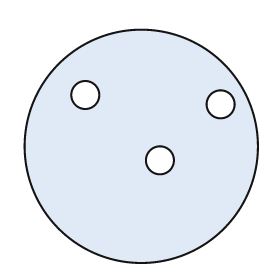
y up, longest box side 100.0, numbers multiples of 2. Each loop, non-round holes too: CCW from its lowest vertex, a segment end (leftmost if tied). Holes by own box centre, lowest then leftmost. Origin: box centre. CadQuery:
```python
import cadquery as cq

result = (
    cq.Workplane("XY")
    .moveTo(0.0, 0.0)
    .circle(50.0)
    .moveTo(8.0, -6.0)
    .circle(6.0)
    .moveTo(34.0, 18.0)
    .circle(6.0)
    .moveTo(-24.0, 22.0)
    .circle(6.0)
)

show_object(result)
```